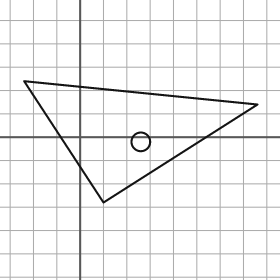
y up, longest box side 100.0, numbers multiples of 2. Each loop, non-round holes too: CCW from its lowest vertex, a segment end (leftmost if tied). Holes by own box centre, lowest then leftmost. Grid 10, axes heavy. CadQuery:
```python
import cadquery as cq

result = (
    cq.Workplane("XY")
    .moveTo(10.0, -28.0)
    .lineTo(76.0, 14.0)
    .lineTo(-24.0, 24.0)
    .close()
    .moveTo(26.0, -2.0)
    .circle(4.0)
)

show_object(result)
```